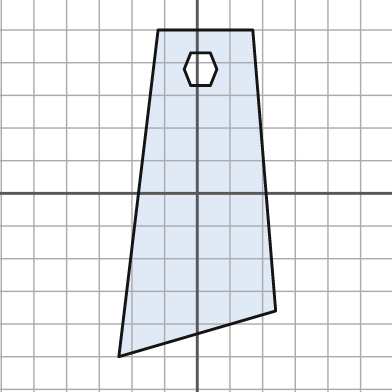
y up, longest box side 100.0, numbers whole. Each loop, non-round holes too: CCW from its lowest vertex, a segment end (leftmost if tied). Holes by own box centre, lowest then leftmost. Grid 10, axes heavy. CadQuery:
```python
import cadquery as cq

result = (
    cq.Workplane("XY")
    .moveTo(-24.0, -50.0)
    .lineTo(24.0, -36.0)
    .lineTo(17.0, 50.0)
    .lineTo(-12.0, 50.0)
    .close()
    .moveTo(-2.0, 33.0)
    .lineTo(4.0, 33.0)
    .lineTo(6.0, 38.0)
    .lineTo(4.0, 43.0)
    .lineTo(-2.0, 43.0)
    .lineTo(-4.0, 38.0)
    .close()
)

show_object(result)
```